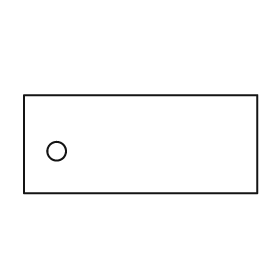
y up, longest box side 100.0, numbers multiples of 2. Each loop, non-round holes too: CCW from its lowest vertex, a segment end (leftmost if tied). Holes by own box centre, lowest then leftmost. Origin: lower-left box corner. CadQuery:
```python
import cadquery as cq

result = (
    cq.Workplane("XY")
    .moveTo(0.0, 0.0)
    .lineTo(100.0, 0.0)
    .lineTo(100.0, 42.0)
    .lineTo(0.0, 42.0)
    .close()
    .moveTo(14.0, 18.0)
    .circle(4.0)
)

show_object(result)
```